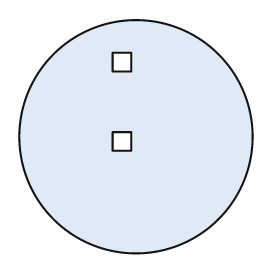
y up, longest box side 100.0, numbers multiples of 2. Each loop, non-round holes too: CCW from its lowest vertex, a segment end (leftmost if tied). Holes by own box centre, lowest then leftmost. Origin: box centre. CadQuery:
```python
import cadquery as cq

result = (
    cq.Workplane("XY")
    .moveTo(0.0, 0.0)
    .circle(50.0)
    .moveTo(-10.0, -6.0)
    .lineTo(-2.0, -6.0)
    .lineTo(-2.0, 2.0)
    .lineTo(-10.0, 2.0)
    .close()
    .moveTo(-10.0, 28.0)
    .lineTo(-2.0, 28.0)
    .lineTo(-2.0, 36.0)
    .lineTo(-10.0, 36.0)
    .close()
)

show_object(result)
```